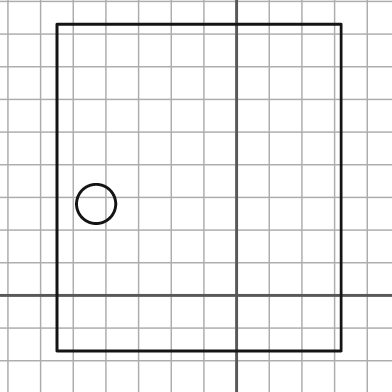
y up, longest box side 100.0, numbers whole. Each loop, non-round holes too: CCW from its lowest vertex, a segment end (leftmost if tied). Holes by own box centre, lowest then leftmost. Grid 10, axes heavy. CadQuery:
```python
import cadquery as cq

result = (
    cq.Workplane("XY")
    .moveTo(-55.0, -17.0)
    .lineTo(32.0, -17.0)
    .lineTo(32.0, 83.0)
    .lineTo(-55.0, 83.0)
    .close()
    .moveTo(-43.0, 28.0)
    .circle(6.0)
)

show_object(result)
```